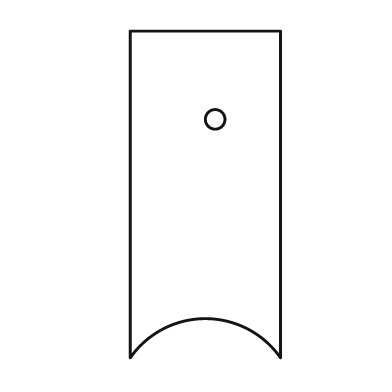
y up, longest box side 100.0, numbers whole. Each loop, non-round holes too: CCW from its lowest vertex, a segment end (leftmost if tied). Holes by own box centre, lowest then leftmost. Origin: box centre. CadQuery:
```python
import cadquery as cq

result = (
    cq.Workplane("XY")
    .moveTo(-23.0, -50.0)
    .threePointArc((0.0, -38.0), (23.0, -50.0))
    .lineTo(23.0, 50.0)
    .lineTo(-23.0, 50.0)
    .close()
    .moveTo(3.0, 23.0)
    .circle(3.0)
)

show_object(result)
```